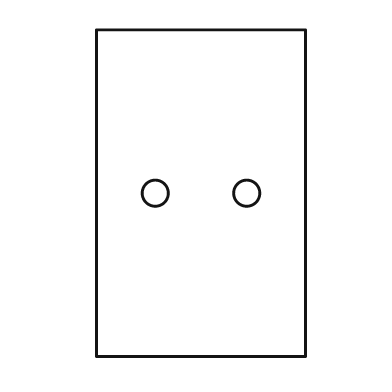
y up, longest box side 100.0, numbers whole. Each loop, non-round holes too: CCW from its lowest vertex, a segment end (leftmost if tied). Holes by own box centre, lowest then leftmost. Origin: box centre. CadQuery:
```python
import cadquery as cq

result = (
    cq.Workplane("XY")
    .moveTo(-32.0, -50.0)
    .lineTo(32.0, -50.0)
    .lineTo(32.0, 50.0)
    .lineTo(-32.0, 50.0)
    .close()
    .moveTo(-14.0, 0.0)
    .circle(4.0)
    .moveTo(14.0, 0.0)
    .circle(4.0)
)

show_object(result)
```